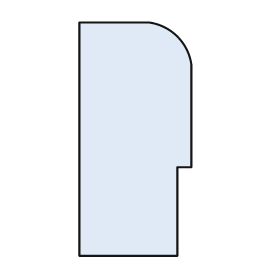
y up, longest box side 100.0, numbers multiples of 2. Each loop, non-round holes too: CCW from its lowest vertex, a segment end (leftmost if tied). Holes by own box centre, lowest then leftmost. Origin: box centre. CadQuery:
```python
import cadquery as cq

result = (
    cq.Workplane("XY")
    .moveTo(-24.0, -50.0)
    .lineTo(18.0, -50.0)
    .lineTo(18.0, -12.0)
    .lineTo(24.0, -12.0)
    .lineTo(24.0, 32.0)
    .threePointArc((18.0, 44.0), (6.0, 50.0))
    .lineTo(-24.0, 50.0)
    .close()
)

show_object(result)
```